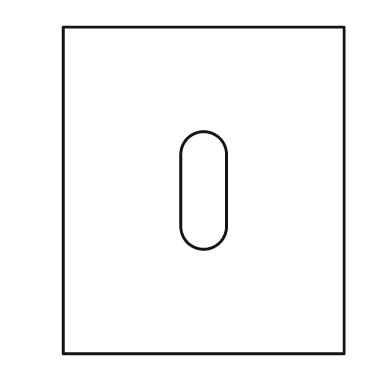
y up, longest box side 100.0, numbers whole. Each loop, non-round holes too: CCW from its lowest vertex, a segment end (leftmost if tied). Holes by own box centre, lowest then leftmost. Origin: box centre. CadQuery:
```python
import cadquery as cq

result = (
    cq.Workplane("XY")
    .moveTo(-43.0, -50.0)
    .lineTo(43.0, -50.0)
    .lineTo(43.0, 50.0)
    .lineTo(-43.0, 50.0)
    .close()
    .moveTo(-7.0, -11.0)
    .threePointArc((0.0, -18.0), (7.0, -11.0))
    .lineTo(7.0, 11.0)
    .threePointArc((0.0, 18.0), (-7.0, 11.0))
    .close()
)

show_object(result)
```